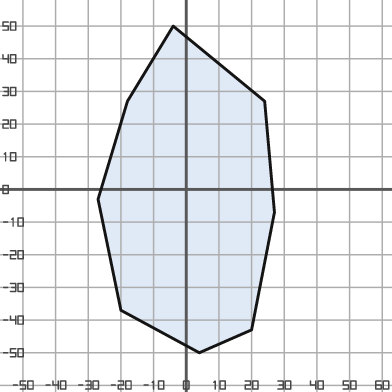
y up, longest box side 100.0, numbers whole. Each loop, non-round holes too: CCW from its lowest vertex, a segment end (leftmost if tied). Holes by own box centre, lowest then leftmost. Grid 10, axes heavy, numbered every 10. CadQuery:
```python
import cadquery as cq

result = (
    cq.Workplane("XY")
    .moveTo(4.0, -50.0)
    .lineTo(20.0, -43.0)
    .lineTo(27.0, -7.0)
    .lineTo(24.0, 27.0)
    .lineTo(-4.0, 50.0)
    .lineTo(-18.0, 27.0)
    .lineTo(-27.0, -3.0)
    .lineTo(-20.0, -37.0)
    .close()
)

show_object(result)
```